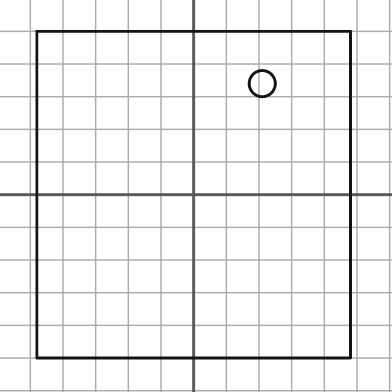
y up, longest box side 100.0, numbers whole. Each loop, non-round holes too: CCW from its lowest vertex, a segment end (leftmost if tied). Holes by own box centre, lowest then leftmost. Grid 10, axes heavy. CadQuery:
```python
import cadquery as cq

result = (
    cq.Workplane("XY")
    .moveTo(-48.0, -50.0)
    .lineTo(48.0, -50.0)
    .lineTo(48.0, 50.0)
    .lineTo(-48.0, 50.0)
    .close()
    .moveTo(21.0, 34.0)
    .circle(4.0)
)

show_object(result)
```